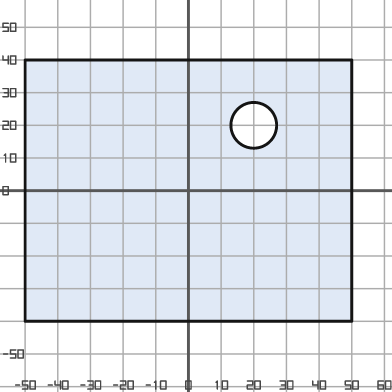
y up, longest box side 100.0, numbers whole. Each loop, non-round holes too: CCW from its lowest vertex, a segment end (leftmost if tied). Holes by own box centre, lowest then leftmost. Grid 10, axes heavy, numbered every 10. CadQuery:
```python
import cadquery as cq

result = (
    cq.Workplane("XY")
    .moveTo(-50.0, -40.0)
    .lineTo(50.0, -40.0)
    .lineTo(50.0, 40.0)
    .lineTo(-50.0, 40.0)
    .close()
    .moveTo(20.0, 20.0)
    .circle(7.0)
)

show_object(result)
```